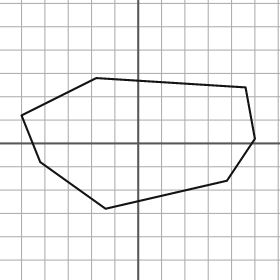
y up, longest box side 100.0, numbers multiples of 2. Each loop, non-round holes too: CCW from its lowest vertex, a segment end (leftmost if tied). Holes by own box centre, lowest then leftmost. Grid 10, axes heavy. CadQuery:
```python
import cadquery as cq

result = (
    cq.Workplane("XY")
    .moveTo(-14.0, -28.0)
    .lineTo(38.0, -16.0)
    .lineTo(50.0, 2.0)
    .lineTo(46.0, 24.0)
    .lineTo(-18.0, 28.0)
    .lineTo(-50.0, 12.0)
    .lineTo(-42.0, -8.0)
    .close()
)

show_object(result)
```